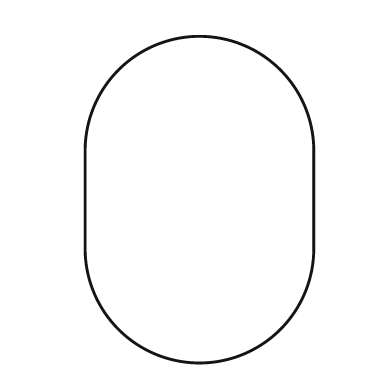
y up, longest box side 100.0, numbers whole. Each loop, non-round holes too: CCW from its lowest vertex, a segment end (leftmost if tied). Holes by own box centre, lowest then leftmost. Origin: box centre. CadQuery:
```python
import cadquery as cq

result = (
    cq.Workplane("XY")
    .moveTo(-35.0, -15.0)
    .threePointArc((0.0, -50.0), (35.0, -15.0))
    .lineTo(35.0, 15.0)
    .threePointArc((0.0, 50.0), (-35.0, 15.0))
    .close()
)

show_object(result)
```